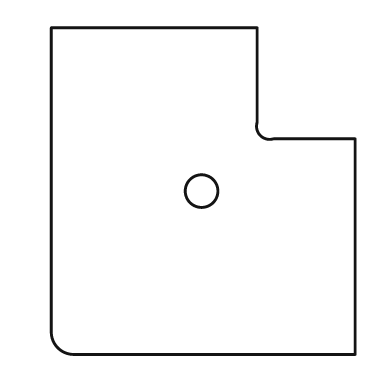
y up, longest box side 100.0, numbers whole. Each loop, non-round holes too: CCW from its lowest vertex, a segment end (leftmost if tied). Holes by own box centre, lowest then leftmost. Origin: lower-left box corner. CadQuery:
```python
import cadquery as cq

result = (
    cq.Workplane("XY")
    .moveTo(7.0, 0.0)
    .lineTo(93.0, 0.0)
    .lineTo(93.0, 66.0)
    .lineTo(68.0, 66.0)
    .threePointArc((64.0, 67.0), (63.0, 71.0))
    .lineTo(63.0, 100.0)
    .lineTo(0.0, 100.0)
    .lineTo(0.0, 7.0)
    .threePointArc((2.0, 2.0), (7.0, 0.0))
    .close()
    .moveTo(46.0, 50.0)
    .circle(5.0)
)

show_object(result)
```